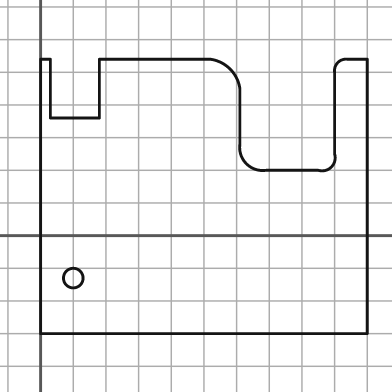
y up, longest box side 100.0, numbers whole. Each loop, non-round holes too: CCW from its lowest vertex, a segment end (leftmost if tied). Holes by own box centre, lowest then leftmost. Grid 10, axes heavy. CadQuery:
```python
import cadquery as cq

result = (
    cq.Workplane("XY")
    .moveTo(0.0, -30.0)
    .lineTo(100.0, -30.0)
    .lineTo(100.0, 54.0)
    .lineTo(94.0, 54.0)
    .threePointArc((91.0, 53.0), (90.0, 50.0))
    .lineTo(90.0, 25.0)
    .threePointArc((89.0, 21.0), (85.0, 20.0))
    .lineTo(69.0, 20.0)
    .threePointArc((63.0, 22.0), (61.0, 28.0))
    .lineTo(61.0, 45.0)
    .threePointArc((58.0, 51.0), (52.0, 54.0))
    .lineTo(18.0, 54.0)
    .lineTo(18.0, 36.0)
    .lineTo(3.0, 36.0)
    .lineTo(3.0, 54.0)
    .lineTo(0.0, 54.0)
    .close()
    .moveTo(10.0, -13.0)
    .circle(3.0)
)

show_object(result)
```